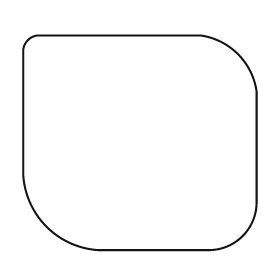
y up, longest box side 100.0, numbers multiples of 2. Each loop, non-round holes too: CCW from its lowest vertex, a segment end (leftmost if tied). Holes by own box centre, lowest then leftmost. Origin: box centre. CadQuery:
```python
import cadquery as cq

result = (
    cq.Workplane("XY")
    .moveTo(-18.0, -46.0)
    .lineTo(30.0, -46.0)
    .threePointArc((44.0, -40.0), (50.0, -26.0))
    .lineTo(50.0, 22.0)
    .threePointArc((42.0, 38.0), (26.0, 46.0))
    .lineTo(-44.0, 46.0)
    .threePointArc((-48.0, 44.0), (-50.0, 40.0))
    .lineTo(-50.0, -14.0)
    .threePointArc((-40.0, -36.0), (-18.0, -46.0))
    .close()
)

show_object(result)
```